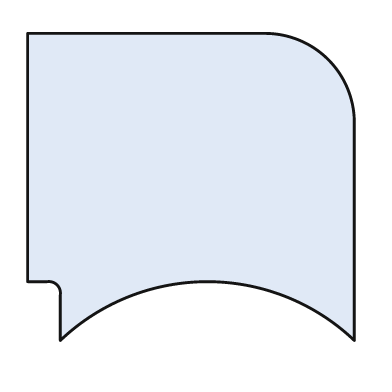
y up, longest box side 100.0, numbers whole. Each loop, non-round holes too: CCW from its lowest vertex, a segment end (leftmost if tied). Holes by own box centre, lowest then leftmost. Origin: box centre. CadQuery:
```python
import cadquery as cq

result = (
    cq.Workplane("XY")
    .moveTo(-40.0, -47.0)
    .threePointArc((5.0, -29.0), (50.0, -47.0))
    .lineTo(50.0, 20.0)
    .threePointArc((42.0, 39.0), (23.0, 47.0))
    .lineTo(-50.0, 47.0)
    .lineTo(-50.0, -29.0)
    .lineTo(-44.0, -29.0)
    .threePointArc((-41.0, -30.0), (-40.0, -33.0))
    .close()
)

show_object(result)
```